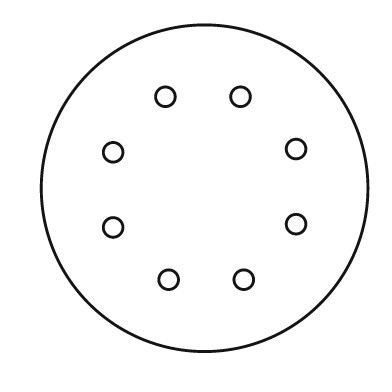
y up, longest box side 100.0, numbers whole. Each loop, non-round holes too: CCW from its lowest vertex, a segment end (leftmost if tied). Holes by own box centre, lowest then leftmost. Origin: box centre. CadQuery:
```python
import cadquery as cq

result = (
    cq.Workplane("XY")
    .moveTo(0.0, 0.0)
    .circle(50.0)
    .moveTo(-11.0, -28.0)
    .circle(3.0)
    .moveTo(12.0, -28.0)
    .circle(3.0)
    .moveTo(-28.0, -12.0)
    .circle(3.0)
    .moveTo(28.0, -11.0)
    .circle(3.0)
    .moveTo(-28.0, 11.0)
    .circle(3.0)
    .moveTo(28.0, 12.0)
    .circle(3.0)
    .moveTo(-12.0, 28.0)
    .circle(3.0)
    .moveTo(11.0, 28.0)
    .circle(3.0)
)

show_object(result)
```